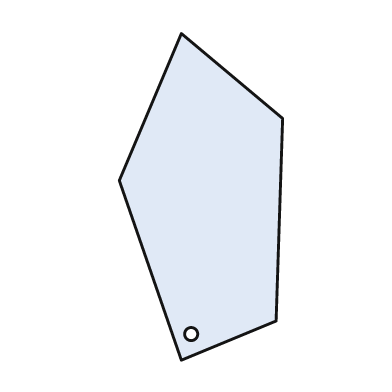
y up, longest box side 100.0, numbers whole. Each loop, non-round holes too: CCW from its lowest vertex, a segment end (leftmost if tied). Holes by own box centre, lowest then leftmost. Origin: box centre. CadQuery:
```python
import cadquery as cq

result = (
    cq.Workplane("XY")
    .moveTo(-6.0, -50.0)
    .lineTo(23.0, -38.0)
    .lineTo(25.0, 24.0)
    .lineTo(-6.0, 50.0)
    .lineTo(-25.0, 5.0)
    .close()
    .moveTo(-3.0, -42.0)
    .circle(2.0)
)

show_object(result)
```